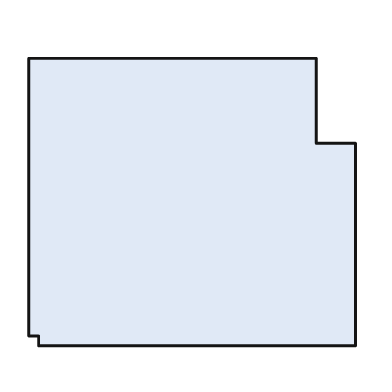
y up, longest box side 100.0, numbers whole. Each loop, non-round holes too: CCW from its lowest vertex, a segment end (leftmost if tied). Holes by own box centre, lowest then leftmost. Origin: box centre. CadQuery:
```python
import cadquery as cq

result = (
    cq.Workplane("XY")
    .moveTo(-47.0, -44.0)
    .lineTo(50.0, -44.0)
    .lineTo(50.0, 18.0)
    .lineTo(38.0, 18.0)
    .lineTo(38.0, 44.0)
    .lineTo(-50.0, 44.0)
    .lineTo(-50.0, -41.0)
    .lineTo(-47.0, -41.0)
    .close()
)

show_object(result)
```